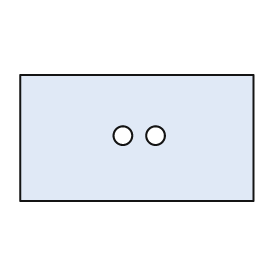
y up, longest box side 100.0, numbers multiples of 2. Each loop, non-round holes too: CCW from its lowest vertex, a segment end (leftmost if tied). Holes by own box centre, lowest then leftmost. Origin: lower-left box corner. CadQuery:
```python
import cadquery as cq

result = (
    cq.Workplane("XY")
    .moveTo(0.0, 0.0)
    .lineTo(100.0, 0.0)
    .lineTo(100.0, 54.0)
    .lineTo(0.0, 54.0)
    .close()
    .moveTo(44.0, 28.0)
    .circle(4.0)
    .moveTo(58.0, 28.0)
    .circle(4.0)
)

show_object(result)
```